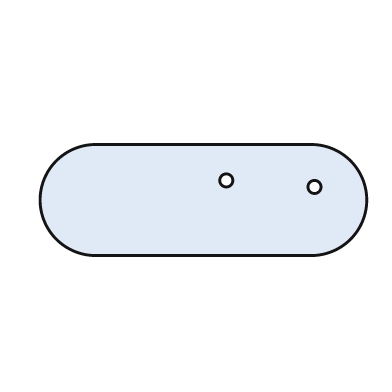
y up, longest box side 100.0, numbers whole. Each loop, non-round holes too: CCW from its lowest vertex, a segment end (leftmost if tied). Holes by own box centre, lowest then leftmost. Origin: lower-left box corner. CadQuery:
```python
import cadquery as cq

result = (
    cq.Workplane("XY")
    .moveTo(17.0, 0.0)
    .lineTo(83.0, 0.0)
    .threePointArc((100.0, 17.0), (83.0, 34.0))
    .lineTo(17.0, 34.0)
    .threePointArc((0.0, 17.0), (17.0, 0.0))
    .close()
    .moveTo(84.0, 21.0)
    .circle(2.0)
    .moveTo(57.0, 23.0)
    .circle(2.0)
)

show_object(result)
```